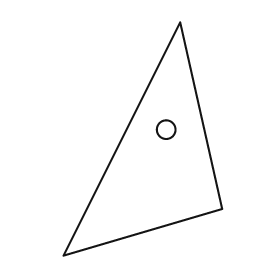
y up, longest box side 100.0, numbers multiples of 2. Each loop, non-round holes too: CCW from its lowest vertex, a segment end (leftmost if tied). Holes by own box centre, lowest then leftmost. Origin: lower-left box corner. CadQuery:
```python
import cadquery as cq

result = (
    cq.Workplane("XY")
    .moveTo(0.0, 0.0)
    .lineTo(68.0, 20.0)
    .lineTo(50.0, 100.0)
    .close()
    .moveTo(44.0, 54.0)
    .circle(4.0)
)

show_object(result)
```